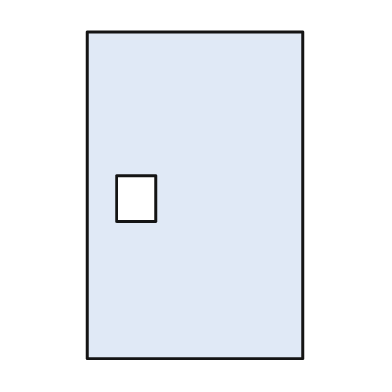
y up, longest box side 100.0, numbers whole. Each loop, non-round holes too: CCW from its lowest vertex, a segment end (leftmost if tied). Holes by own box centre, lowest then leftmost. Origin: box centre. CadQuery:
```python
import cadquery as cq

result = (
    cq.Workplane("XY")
    .moveTo(-33.0, -50.0)
    .lineTo(33.0, -50.0)
    .lineTo(33.0, 50.0)
    .lineTo(-33.0, 50.0)
    .close()
    .moveTo(-24.0, -8.0)
    .lineTo(-12.0, -8.0)
    .lineTo(-12.0, 6.0)
    .lineTo(-24.0, 6.0)
    .close()
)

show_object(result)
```